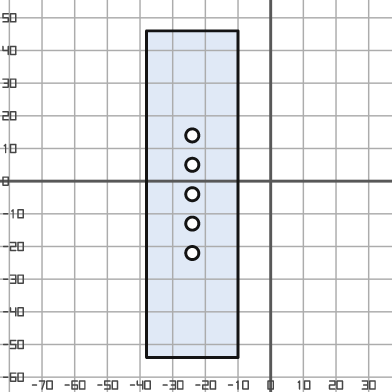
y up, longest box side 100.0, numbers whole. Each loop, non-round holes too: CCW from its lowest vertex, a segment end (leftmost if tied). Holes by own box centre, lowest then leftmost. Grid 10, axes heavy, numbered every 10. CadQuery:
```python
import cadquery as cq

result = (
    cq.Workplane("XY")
    .moveTo(-38.0, -54.0)
    .lineTo(-10.0, -54.0)
    .lineTo(-10.0, 46.0)
    .lineTo(-38.0, 46.0)
    .close()
    .moveTo(-24.0, -22.0)
    .circle(2.0)
    .moveTo(-24.0, -13.0)
    .circle(2.0)
    .moveTo(-24.0, -4.0)
    .circle(2.0)
    .moveTo(-24.0, 5.0)
    .circle(2.0)
    .moveTo(-24.0, 14.0)
    .circle(2.0)
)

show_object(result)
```